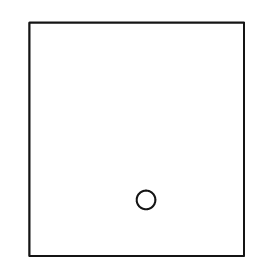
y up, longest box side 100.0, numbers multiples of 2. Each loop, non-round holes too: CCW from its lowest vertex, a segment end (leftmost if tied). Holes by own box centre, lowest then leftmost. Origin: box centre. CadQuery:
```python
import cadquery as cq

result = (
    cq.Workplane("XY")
    .moveTo(-46.0, -50.0)
    .lineTo(46.0, -50.0)
    .lineTo(46.0, 50.0)
    .lineTo(-46.0, 50.0)
    .close()
    .moveTo(4.0, -26.0)
    .circle(4.0)
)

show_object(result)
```